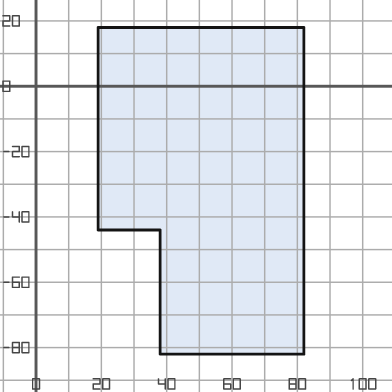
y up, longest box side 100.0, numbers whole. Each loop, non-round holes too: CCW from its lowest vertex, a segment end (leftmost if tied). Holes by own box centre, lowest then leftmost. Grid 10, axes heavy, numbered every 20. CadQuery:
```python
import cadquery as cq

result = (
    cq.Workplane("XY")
    .moveTo(38.0, -82.0)
    .lineTo(82.0, -82.0)
    .lineTo(82.0, 18.0)
    .lineTo(19.0, 18.0)
    .lineTo(19.0, -44.0)
    .lineTo(38.0, -44.0)
    .close()
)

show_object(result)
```